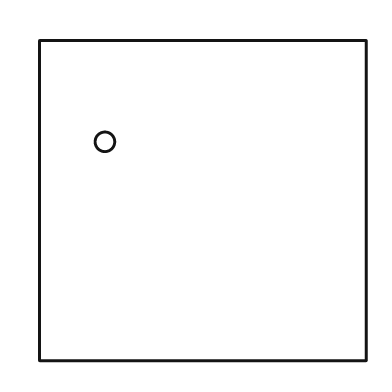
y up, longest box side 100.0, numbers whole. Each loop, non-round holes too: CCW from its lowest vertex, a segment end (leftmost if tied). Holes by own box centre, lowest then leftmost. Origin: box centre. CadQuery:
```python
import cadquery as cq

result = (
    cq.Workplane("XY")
    .moveTo(-50.0, -49.0)
    .lineTo(50.0, -49.0)
    .lineTo(50.0, 49.0)
    .lineTo(-50.0, 49.0)
    .close()
    .moveTo(-30.0, 18.0)
    .circle(3.0)
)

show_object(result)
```